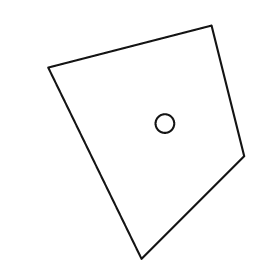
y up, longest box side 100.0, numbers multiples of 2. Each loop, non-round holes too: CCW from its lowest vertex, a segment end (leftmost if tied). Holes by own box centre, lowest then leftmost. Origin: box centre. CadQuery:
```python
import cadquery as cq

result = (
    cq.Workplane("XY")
    .moveTo(-2.0, -50.0)
    .lineTo(42.0, -6.0)
    .lineTo(28.0, 50.0)
    .lineTo(-42.0, 32.0)
    .close()
    .moveTo(8.0, 8.0)
    .circle(4.0)
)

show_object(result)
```